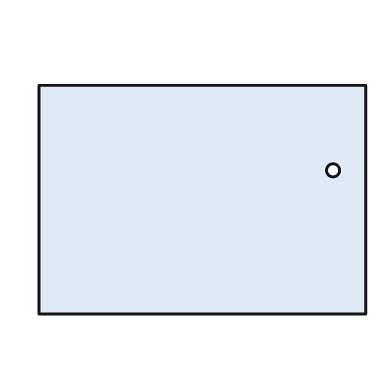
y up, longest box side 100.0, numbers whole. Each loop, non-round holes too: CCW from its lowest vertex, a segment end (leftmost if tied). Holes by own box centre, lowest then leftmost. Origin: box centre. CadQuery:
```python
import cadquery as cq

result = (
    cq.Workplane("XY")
    .moveTo(-50.0, -35.0)
    .lineTo(50.0, -35.0)
    .lineTo(50.0, 35.0)
    .lineTo(-50.0, 35.0)
    .close()
    .moveTo(40.0, 9.0)
    .circle(2.0)
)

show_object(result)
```